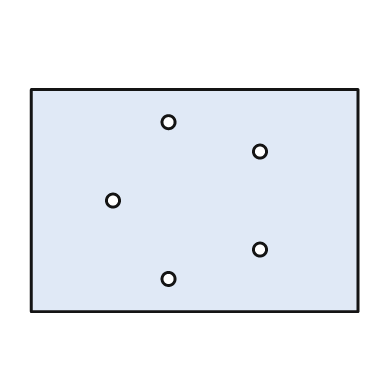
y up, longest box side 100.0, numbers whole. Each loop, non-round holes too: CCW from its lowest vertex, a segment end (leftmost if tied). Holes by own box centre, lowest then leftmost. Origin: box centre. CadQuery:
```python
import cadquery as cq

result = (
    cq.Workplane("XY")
    .moveTo(-50.0, -34.0)
    .lineTo(50.0, -34.0)
    .lineTo(50.0, 34.0)
    .lineTo(-50.0, 34.0)
    .close()
    .moveTo(-8.0, -24.0)
    .circle(2.0)
    .moveTo(20.0, -15.0)
    .circle(2.0)
    .moveTo(-25.0, 0.0)
    .circle(2.0)
    .moveTo(20.0, 15.0)
    .circle(2.0)
    .moveTo(-8.0, 24.0)
    .circle(2.0)
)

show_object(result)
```